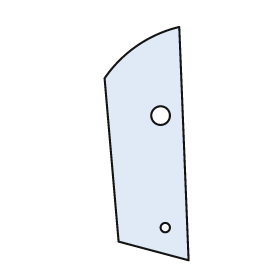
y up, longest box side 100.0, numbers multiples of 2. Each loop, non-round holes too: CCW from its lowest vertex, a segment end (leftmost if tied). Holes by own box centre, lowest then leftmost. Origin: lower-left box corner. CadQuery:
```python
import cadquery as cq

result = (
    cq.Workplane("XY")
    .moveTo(36.0, 0.0)
    .lineTo(32.0, 100.0)
    .threePointArc((14.0, 92.0), (0.0, 78.0))
    .lineTo(6.0, 8.0)
    .close()
    .moveTo(26.0, 14.0)
    .circle(2.0)
    .moveTo(24.0, 62.0)
    .circle(4.0)
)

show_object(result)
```